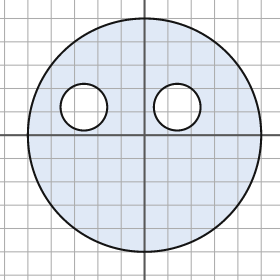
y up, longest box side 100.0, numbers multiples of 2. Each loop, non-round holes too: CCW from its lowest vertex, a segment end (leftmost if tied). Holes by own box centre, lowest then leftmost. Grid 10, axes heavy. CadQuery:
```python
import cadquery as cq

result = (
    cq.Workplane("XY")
    .moveTo(0.0, 0.0)
    .circle(50.0)
    .moveTo(-26.0, 12.0)
    .circle(10.0)
    .moveTo(14.0, 12.0)
    .circle(10.0)
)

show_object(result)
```